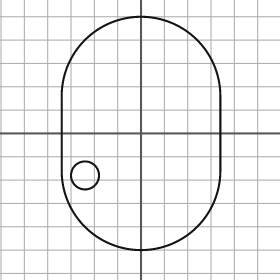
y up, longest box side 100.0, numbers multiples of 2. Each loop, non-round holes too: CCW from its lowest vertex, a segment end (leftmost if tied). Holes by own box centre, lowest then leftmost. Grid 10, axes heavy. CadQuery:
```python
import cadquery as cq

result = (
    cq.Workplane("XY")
    .moveTo(-34.0, -16.0)
    .threePointArc((0.0, -50.0), (34.0, -16.0))
    .lineTo(34.0, 16.0)
    .threePointArc((0.0, 50.0), (-34.0, 16.0))
    .close()
    .moveTo(-24.0, -18.0)
    .circle(6.0)
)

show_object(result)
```